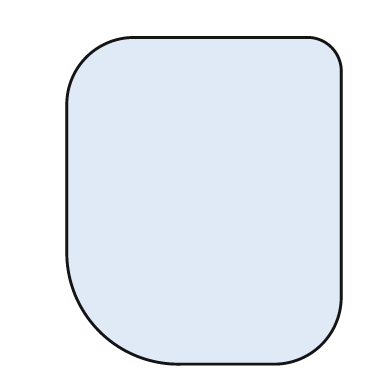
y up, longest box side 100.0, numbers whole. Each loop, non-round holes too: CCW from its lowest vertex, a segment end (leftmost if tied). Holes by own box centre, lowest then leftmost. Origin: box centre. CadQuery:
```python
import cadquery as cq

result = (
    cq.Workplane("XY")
    .moveTo(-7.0, -50.0)
    .lineTo(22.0, -50.0)
    .threePointArc((36.0, -44.0), (42.0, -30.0))
    .lineTo(42.0, 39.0)
    .threePointArc((39.0, 47.0), (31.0, 50.0))
    .lineTo(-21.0, 50.0)
    .threePointArc((-36.0, 44.0), (-42.0, 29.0))
    .lineTo(-42.0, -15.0)
    .threePointArc((-32.0, -40.0), (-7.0, -50.0))
    .close()
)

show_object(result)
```